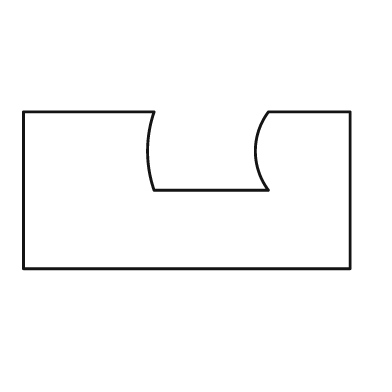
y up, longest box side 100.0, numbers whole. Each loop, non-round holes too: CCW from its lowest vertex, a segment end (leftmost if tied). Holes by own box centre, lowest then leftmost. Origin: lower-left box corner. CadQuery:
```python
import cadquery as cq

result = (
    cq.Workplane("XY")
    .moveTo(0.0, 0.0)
    .lineTo(100.0, 0.0)
    .lineTo(100.0, 48.0)
    .lineTo(75.0, 48.0)
    .threePointArc((71.0, 36.0), (75.0, 24.0))
    .lineTo(40.0, 24.0)
    .threePointArc((38.0, 36.0), (40.0, 48.0))
    .lineTo(0.0, 48.0)
    .close()
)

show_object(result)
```